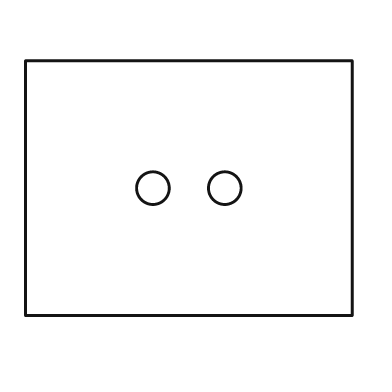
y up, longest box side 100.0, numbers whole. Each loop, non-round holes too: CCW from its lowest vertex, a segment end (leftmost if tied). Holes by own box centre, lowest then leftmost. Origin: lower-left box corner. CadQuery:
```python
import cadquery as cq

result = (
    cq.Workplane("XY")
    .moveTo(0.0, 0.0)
    .lineTo(100.0, 0.0)
    .lineTo(100.0, 78.0)
    .lineTo(0.0, 78.0)
    .close()
    .moveTo(39.0, 39.0)
    .circle(5.0)
    .moveTo(61.0, 39.0)
    .circle(5.0)
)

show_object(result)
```